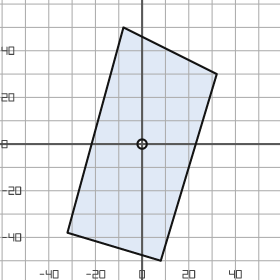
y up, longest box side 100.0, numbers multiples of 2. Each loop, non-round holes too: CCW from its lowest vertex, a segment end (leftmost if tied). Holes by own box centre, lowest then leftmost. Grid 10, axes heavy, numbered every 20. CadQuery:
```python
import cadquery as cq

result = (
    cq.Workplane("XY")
    .moveTo(8.0, -50.0)
    .lineTo(32.0, 30.0)
    .lineTo(-8.0, 50.0)
    .lineTo(-32.0, -38.0)
    .close()
    .moveTo(0.0, 0.0)
    .circle(2.0)
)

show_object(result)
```